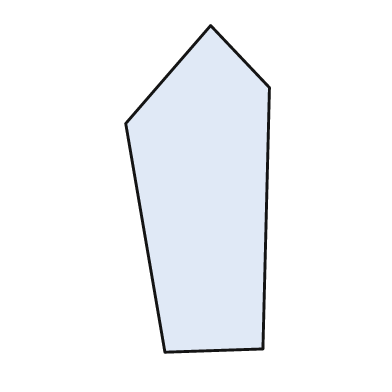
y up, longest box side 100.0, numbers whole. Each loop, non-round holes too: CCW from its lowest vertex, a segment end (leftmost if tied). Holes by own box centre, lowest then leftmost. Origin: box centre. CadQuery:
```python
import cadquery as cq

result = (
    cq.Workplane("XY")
    .moveTo(-10.0, -50.0)
    .lineTo(20.0, -49.0)
    .lineTo(22.0, 31.0)
    .lineTo(4.0, 50.0)
    .lineTo(-22.0, 20.0)
    .close()
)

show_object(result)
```